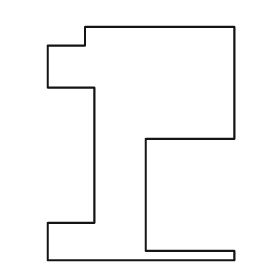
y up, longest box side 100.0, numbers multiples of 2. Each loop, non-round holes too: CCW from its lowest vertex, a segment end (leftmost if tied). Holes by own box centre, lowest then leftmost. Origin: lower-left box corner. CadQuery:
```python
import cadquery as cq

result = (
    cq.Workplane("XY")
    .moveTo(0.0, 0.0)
    .lineTo(80.0, 0.0)
    .lineTo(80.0, 4.0)
    .lineTo(42.0, 4.0)
    .lineTo(42.0, 52.0)
    .lineTo(80.0, 52.0)
    .lineTo(80.0, 100.0)
    .lineTo(16.0, 100.0)
    .lineTo(16.0, 92.0)
    .lineTo(0.0, 92.0)
    .lineTo(0.0, 74.0)
    .lineTo(20.0, 74.0)
    .lineTo(20.0, 16.0)
    .lineTo(0.0, 16.0)
    .close()
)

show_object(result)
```